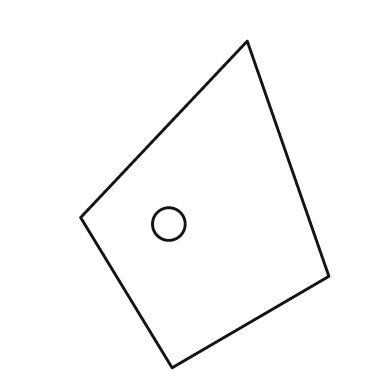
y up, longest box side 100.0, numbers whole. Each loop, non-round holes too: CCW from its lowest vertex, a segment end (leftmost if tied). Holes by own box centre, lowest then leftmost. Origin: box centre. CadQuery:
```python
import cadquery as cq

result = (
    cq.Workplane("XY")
    .moveTo(-10.0, -50.0)
    .lineTo(38.0, -22.0)
    .lineTo(13.0, 50.0)
    .lineTo(-38.0, -4.0)
    .close()
    .moveTo(-11.0, -6.0)
    .circle(5.0)
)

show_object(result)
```